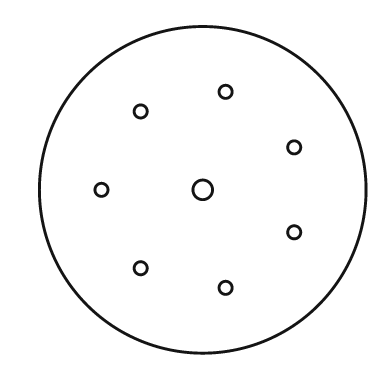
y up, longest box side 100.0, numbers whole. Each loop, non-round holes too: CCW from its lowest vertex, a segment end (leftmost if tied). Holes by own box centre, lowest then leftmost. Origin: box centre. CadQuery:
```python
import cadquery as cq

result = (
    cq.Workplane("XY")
    .moveTo(0.0, 0.0)
    .circle(50.0)
    .moveTo(7.0, -30.0)
    .circle(2.0)
    .moveTo(-19.0, -24.0)
    .circle(2.0)
    .moveTo(28.0, -13.0)
    .circle(2.0)
    .moveTo(-31.0, 0.0)
    .circle(2.0)
    .moveTo(0.0, 0.0)
    .circle(3.0)
    .moveTo(28.0, 13.0)
    .circle(2.0)
    .moveTo(-19.0, 24.0)
    .circle(2.0)
    .moveTo(7.0, 30.0)
    .circle(2.0)
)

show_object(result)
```